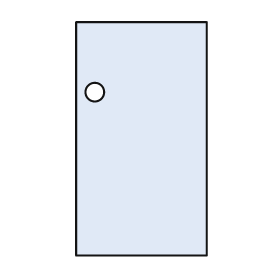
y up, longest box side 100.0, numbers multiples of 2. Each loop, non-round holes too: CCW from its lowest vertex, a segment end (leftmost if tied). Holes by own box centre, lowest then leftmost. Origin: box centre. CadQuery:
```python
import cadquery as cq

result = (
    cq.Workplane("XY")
    .moveTo(-28.0, -50.0)
    .lineTo(28.0, -50.0)
    .lineTo(28.0, 50.0)
    .lineTo(-28.0, 50.0)
    .close()
    .moveTo(-20.0, 20.0)
    .circle(4.0)
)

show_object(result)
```